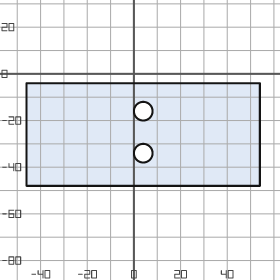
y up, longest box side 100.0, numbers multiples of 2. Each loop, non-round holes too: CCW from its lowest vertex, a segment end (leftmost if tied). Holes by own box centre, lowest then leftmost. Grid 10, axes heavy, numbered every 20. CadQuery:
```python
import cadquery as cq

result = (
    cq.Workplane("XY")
    .moveTo(-46.0, -48.0)
    .lineTo(54.0, -48.0)
    .lineTo(54.0, -4.0)
    .lineTo(-46.0, -4.0)
    .close()
    .moveTo(4.0, -34.0)
    .circle(4.0)
    .moveTo(4.0, -16.0)
    .circle(4.0)
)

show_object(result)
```